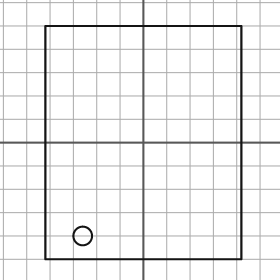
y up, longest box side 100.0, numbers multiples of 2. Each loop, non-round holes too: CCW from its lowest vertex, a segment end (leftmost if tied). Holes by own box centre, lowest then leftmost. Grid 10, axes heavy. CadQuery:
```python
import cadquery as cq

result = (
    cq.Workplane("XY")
    .moveTo(-42.0, -50.0)
    .lineTo(42.0, -50.0)
    .lineTo(42.0, 50.0)
    .lineTo(-42.0, 50.0)
    .close()
    .moveTo(-26.0, -40.0)
    .circle(4.0)
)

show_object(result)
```